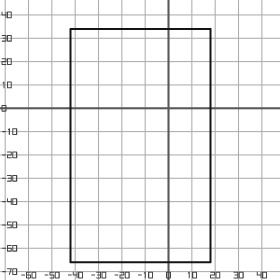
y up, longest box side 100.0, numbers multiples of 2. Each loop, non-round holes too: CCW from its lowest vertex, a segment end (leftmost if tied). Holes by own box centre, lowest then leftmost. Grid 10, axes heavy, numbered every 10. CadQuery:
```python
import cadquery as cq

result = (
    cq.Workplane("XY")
    .moveTo(-42.0, -66.0)
    .lineTo(18.0, -66.0)
    .lineTo(18.0, 34.0)
    .lineTo(-42.0, 34.0)
    .close()
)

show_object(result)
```